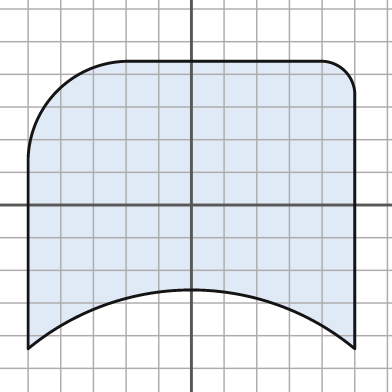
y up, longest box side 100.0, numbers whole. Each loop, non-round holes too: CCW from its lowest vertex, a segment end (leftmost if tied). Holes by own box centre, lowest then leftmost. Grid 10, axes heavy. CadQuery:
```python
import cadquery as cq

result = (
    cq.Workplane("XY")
    .moveTo(-50.0, -44.0)
    .threePointArc((0.0, -26.0), (50.0, -44.0))
    .lineTo(50.0, 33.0)
    .threePointArc((47.0, 41.0), (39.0, 44.0))
    .lineTo(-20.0, 44.0)
    .threePointArc((-41.0, 35.0), (-50.0, 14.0))
    .close()
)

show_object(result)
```